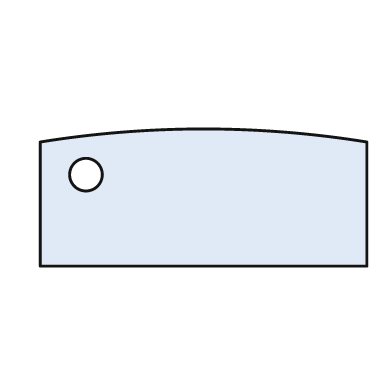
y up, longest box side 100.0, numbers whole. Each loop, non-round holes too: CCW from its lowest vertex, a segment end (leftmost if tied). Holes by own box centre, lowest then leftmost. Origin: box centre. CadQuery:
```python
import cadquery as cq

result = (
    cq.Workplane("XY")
    .moveTo(-50.0, -21.0)
    .lineTo(50.0, -21.0)
    .lineTo(50.0, 17.0)
    .threePointArc((0.0, 21.0), (-50.0, 17.0))
    .close()
    .moveTo(-36.0, 7.0)
    .circle(5.0)
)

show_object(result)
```